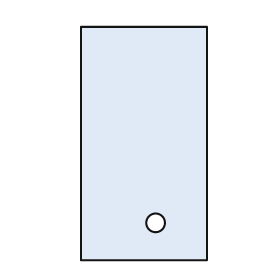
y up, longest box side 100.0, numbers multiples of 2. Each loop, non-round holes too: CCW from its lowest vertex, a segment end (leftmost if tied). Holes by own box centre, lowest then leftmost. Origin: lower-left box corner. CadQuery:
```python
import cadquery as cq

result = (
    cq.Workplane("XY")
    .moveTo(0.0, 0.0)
    .lineTo(54.0, 0.0)
    .lineTo(54.0, 100.0)
    .lineTo(0.0, 100.0)
    .close()
    .moveTo(32.0, 16.0)
    .circle(4.0)
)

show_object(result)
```